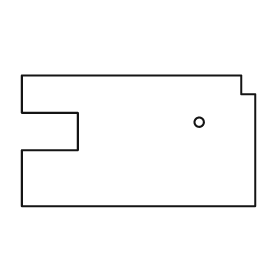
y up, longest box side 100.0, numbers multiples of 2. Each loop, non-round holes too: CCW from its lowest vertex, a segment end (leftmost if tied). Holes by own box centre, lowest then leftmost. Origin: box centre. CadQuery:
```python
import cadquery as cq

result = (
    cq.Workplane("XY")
    .moveTo(-50.0, -28.0)
    .lineTo(50.0, -28.0)
    .lineTo(50.0, 20.0)
    .lineTo(44.0, 20.0)
    .lineTo(44.0, 28.0)
    .lineTo(-50.0, 28.0)
    .lineTo(-50.0, 12.0)
    .lineTo(-26.0, 12.0)
    .lineTo(-26.0, -4.0)
    .lineTo(-50.0, -4.0)
    .close()
    .moveTo(26.0, 8.0)
    .circle(2.0)
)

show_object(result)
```